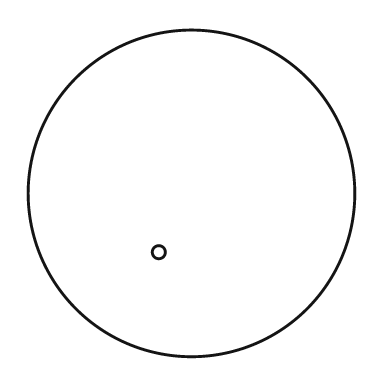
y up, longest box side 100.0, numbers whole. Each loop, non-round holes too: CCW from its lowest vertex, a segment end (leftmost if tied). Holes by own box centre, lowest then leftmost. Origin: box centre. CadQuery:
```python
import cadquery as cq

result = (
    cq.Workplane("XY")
    .moveTo(0.0, 0.0)
    .circle(50.0)
    .moveTo(-10.0, -18.0)
    .circle(2.0)
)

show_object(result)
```